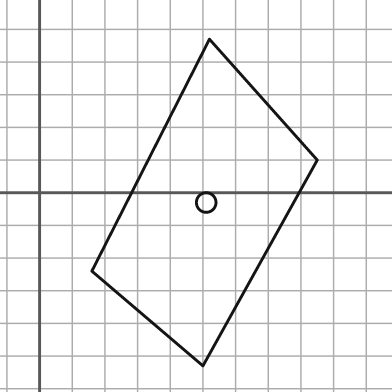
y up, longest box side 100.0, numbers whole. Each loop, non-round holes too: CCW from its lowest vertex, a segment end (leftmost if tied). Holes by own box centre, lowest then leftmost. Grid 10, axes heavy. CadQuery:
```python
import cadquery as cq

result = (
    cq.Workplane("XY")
    .moveTo(50.0, -53.0)
    .lineTo(85.0, 10.0)
    .lineTo(52.0, 47.0)
    .lineTo(16.0, -24.0)
    .close()
    .moveTo(51.0, -3.0)
    .circle(3.0)
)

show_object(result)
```